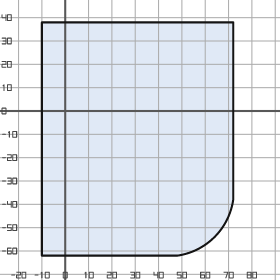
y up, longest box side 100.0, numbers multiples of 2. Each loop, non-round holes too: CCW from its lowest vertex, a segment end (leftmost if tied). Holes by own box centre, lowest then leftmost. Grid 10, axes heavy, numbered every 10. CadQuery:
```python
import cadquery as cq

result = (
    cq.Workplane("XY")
    .moveTo(-10.0, -62.0)
    .lineTo(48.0, -62.0)
    .threePointArc((64.0, -54.0), (72.0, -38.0))
    .lineTo(72.0, 38.0)
    .lineTo(-10.0, 38.0)
    .close()
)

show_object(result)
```